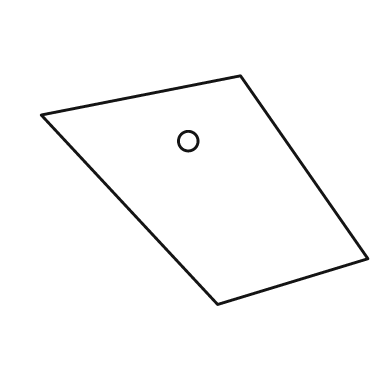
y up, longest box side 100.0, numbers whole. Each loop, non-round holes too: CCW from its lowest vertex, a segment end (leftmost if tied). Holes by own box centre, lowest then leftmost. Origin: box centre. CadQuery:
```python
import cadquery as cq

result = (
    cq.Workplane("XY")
    .moveTo(4.0, -35.0)
    .lineTo(50.0, -21.0)
    .lineTo(11.0, 35.0)
    .lineTo(-50.0, 23.0)
    .close()
    .moveTo(-5.0, 15.0)
    .circle(3.0)
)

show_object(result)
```